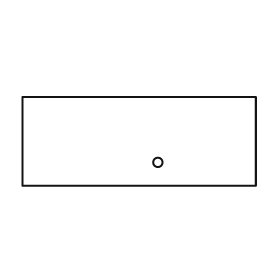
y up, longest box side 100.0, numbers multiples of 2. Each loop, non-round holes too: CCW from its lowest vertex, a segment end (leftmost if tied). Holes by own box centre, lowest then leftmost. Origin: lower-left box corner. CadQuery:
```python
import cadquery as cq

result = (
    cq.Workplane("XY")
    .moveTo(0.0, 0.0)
    .lineTo(100.0, 0.0)
    .lineTo(100.0, 38.0)
    .lineTo(0.0, 38.0)
    .close()
    .moveTo(58.0, 10.0)
    .circle(2.0)
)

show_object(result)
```